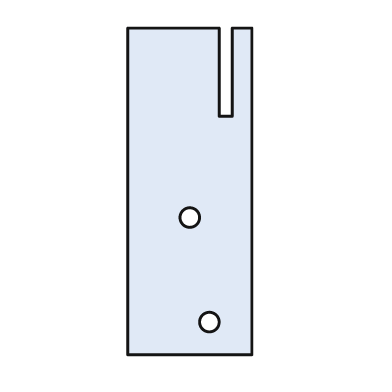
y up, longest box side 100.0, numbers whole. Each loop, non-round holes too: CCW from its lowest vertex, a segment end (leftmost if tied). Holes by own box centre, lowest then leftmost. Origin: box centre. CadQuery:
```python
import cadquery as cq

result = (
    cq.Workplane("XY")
    .moveTo(-19.0, -50.0)
    .lineTo(19.0, -50.0)
    .lineTo(19.0, 50.0)
    .lineTo(13.0, 50.0)
    .lineTo(13.0, 23.0)
    .lineTo(9.0, 23.0)
    .lineTo(9.0, 50.0)
    .lineTo(-19.0, 50.0)
    .close()
    .moveTo(6.0, -40.0)
    .circle(3.0)
    .moveTo(0.0, -8.0)
    .circle(3.0)
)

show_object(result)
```